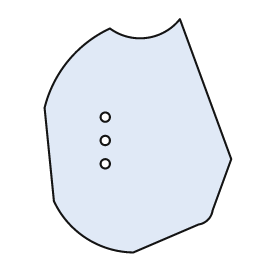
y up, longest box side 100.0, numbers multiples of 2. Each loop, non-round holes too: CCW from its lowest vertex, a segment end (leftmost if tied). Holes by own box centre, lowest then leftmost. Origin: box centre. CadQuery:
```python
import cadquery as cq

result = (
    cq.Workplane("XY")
    .moveTo(-2.0, -50.0)
    .lineTo(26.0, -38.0)
    .threePointArc((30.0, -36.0), (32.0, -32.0))
    .lineTo(40.0, -10.0)
    .lineTo(18.0, 50.0)
    .threePointArc((4.0, 42.0), (-12.0, 46.0))
    .threePointArc((-30.0, 32.0), (-40.0, 12.0))
    .lineTo(-36.0, -28.0)
    .threePointArc((-22.0, -44.0), (-2.0, -50.0))
    .close()
    .moveTo(-14.0, -12.0)
    .circle(2.0)
    .moveTo(-14.0, -2.0)
    .circle(2.0)
    .moveTo(-14.0, 8.0)
    .circle(2.0)
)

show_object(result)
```